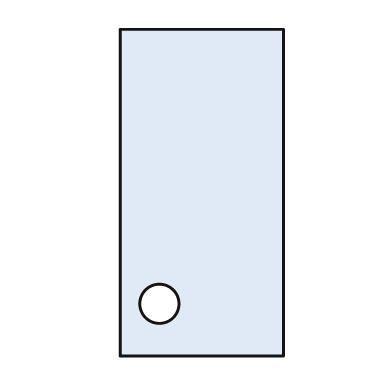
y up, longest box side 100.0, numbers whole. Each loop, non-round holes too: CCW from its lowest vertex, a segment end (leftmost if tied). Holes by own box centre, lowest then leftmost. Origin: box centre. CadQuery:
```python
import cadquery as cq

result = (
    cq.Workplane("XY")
    .moveTo(-25.0, -50.0)
    .lineTo(25.0, -50.0)
    .lineTo(25.0, 50.0)
    .lineTo(-25.0, 50.0)
    .close()
    .moveTo(-13.0, -34.0)
    .circle(6.0)
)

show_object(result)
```